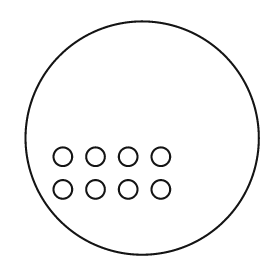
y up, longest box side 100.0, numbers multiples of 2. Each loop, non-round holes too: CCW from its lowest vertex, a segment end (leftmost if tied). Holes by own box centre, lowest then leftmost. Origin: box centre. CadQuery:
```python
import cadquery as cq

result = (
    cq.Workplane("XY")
    .moveTo(0.0, 0.0)
    .circle(50.0)
    .moveTo(-34.0, -22.0)
    .circle(4.0)
    .moveTo(-20.0, -22.0)
    .circle(4.0)
    .moveTo(-6.0, -22.0)
    .circle(4.0)
    .moveTo(8.0, -22.0)
    .circle(4.0)
    .moveTo(-34.0, -8.0)
    .circle(4.0)
    .moveTo(-20.0, -8.0)
    .circle(4.0)
    .moveTo(-6.0, -8.0)
    .circle(4.0)
    .moveTo(8.0, -8.0)
    .circle(4.0)
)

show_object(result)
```